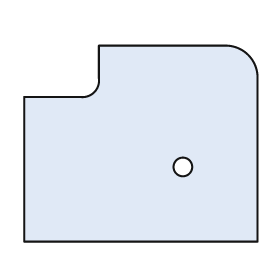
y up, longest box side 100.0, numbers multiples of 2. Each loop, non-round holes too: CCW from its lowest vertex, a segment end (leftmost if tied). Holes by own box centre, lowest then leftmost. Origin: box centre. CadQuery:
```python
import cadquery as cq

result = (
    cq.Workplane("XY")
    .moveTo(-50.0, -42.0)
    .lineTo(50.0, -42.0)
    .lineTo(50.0, 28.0)
    .threePointArc((46.0, 38.0), (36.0, 42.0))
    .lineTo(-18.0, 42.0)
    .lineTo(-18.0, 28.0)
    .threePointArc((-20.0, 22.0), (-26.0, 20.0))
    .lineTo(-50.0, 20.0)
    .close()
    .moveTo(18.0, -10.0)
    .circle(4.0)
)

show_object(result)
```